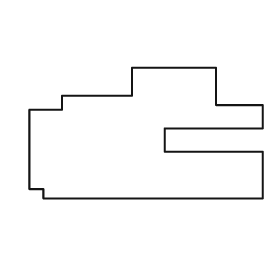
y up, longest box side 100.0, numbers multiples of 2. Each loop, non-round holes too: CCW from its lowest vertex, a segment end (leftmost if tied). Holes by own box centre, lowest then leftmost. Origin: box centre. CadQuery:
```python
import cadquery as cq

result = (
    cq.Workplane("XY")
    .moveTo(-44.0, -28.0)
    .lineTo(50.0, -28.0)
    .lineTo(50.0, -8.0)
    .lineTo(8.0, -8.0)
    .lineTo(8.0, 2.0)
    .lineTo(50.0, 2.0)
    .lineTo(50.0, 12.0)
    .lineTo(30.0, 12.0)
    .lineTo(30.0, 28.0)
    .lineTo(-6.0, 28.0)
    .lineTo(-6.0, 16.0)
    .lineTo(-36.0, 16.0)
    .lineTo(-36.0, 10.0)
    .lineTo(-50.0, 10.0)
    .lineTo(-50.0, -24.0)
    .lineTo(-44.0, -24.0)
    .close()
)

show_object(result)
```